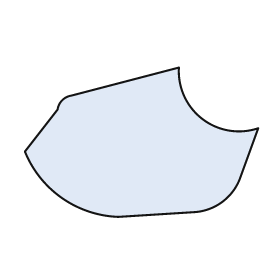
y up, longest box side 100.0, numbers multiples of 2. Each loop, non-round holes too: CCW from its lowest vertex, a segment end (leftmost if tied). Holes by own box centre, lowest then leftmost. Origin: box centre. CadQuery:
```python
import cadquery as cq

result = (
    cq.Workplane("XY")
    .moveTo(-10.0, -32.0)
    .lineTo(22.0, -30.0)
    .threePointArc((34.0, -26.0), (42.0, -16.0))
    .lineTo(50.0, 6.0)
    .threePointArc((26.0, 10.0), (16.0, 32.0))
    .lineTo(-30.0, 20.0)
    .threePointArc((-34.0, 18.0), (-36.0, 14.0))
    .lineTo(-50.0, -4.0)
    .threePointArc((-34.0, -24.0), (-10.0, -32.0))
    .close()
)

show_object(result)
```